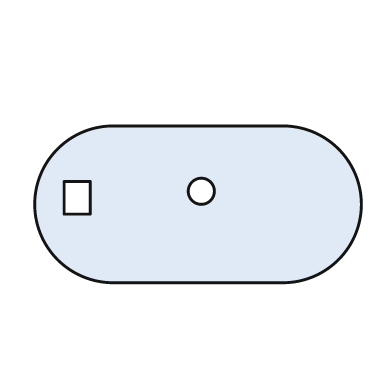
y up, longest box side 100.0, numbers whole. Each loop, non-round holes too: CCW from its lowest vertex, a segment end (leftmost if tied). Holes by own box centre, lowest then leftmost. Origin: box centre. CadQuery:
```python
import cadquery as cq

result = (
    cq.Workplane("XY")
    .moveTo(-26.0, -24.0)
    .lineTo(26.0, -24.0)
    .threePointArc((50.0, 0.0), (26.0, 24.0))
    .lineTo(-26.0, 24.0)
    .threePointArc((-50.0, 0.0), (-26.0, -24.0))
    .close()
    .moveTo(-41.0, -3.0)
    .lineTo(-33.0, -3.0)
    .lineTo(-33.0, 7.0)
    .lineTo(-41.0, 7.0)
    .close()
    .moveTo(1.0, 4.0)
    .circle(4.0)
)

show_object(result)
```